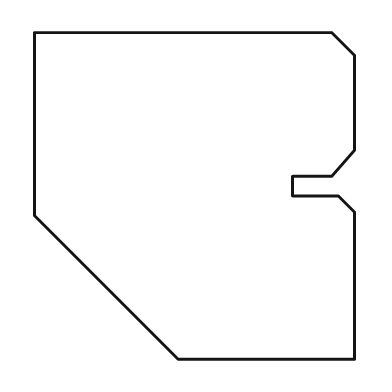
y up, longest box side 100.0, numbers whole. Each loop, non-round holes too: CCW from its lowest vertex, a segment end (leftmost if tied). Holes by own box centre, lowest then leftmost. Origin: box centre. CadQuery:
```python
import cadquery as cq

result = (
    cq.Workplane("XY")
    .moveTo(-5.0, -50.0)
    .lineTo(49.0, -50.0)
    .lineTo(49.0, -5.0)
    .lineTo(44.0, 0.0)
    .lineTo(30.0, 0.0)
    .lineTo(30.0, 6.0)
    .lineTo(42.0, 6.0)
    .lineTo(49.0, 14.0)
    .lineTo(49.0, 43.0)
    .lineTo(42.0, 50.0)
    .lineTo(-49.0, 50.0)
    .lineTo(-49.0, -6.0)
    .close()
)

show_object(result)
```